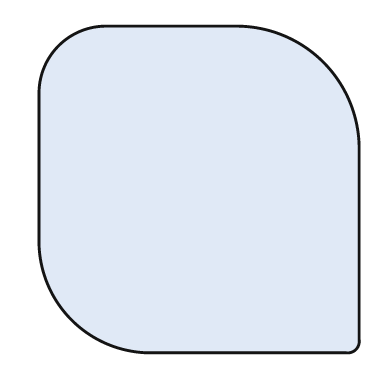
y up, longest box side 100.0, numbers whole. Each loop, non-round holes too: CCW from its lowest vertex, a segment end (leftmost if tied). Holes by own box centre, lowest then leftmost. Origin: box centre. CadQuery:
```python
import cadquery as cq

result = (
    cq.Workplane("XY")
    .moveTo(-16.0, -50.0)
    .lineTo(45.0, -50.0)
    .threePointArc((48.0, -49.0), (49.0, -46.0))
    .lineTo(49.0, 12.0)
    .threePointArc((38.0, 39.0), (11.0, 50.0))
    .lineTo(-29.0, 50.0)
    .threePointArc((-43.0, 44.0), (-49.0, 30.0))
    .lineTo(-49.0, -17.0)
    .threePointArc((-39.0, -40.0), (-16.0, -50.0))
    .close()
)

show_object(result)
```